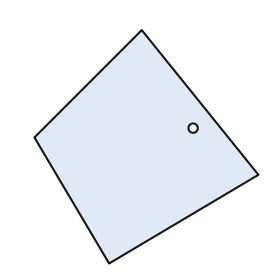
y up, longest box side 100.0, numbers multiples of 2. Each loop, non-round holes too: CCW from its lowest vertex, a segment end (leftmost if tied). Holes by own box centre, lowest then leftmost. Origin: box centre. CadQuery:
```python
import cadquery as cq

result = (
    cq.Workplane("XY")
    .moveTo(-16.0, -50.0)
    .lineTo(48.0, -12.0)
    .lineTo(-2.0, 50.0)
    .lineTo(-48.0, 4.0)
    .close()
    .moveTo(20.0, 8.0)
    .circle(2.0)
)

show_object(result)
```